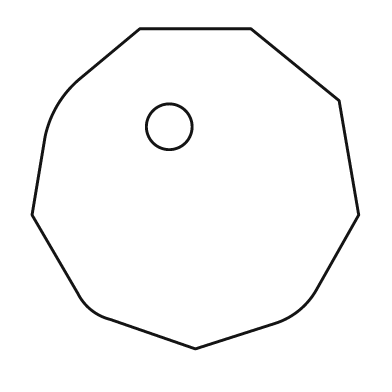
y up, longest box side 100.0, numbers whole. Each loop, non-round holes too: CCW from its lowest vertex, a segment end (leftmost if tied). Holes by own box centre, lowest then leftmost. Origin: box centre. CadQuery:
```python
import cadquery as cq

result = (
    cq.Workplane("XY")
    .moveTo(0.0, -49.0)
    .lineTo(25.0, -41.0)
    .threePointArc((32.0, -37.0), (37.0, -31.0))
    .lineTo(50.0, -8.0)
    .lineTo(44.0, 27.0)
    .lineTo(17.0, 49.0)
    .lineTo(-17.0, 49.0)
    .lineTo(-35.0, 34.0)
    .threePointArc((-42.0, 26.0), (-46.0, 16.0))
    .lineTo(-50.0, -8.0)
    .lineTo(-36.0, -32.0)
    .threePointArc((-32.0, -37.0), (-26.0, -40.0))
    .close()
    .moveTo(-8.0, 19.0)
    .circle(7.0)
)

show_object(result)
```